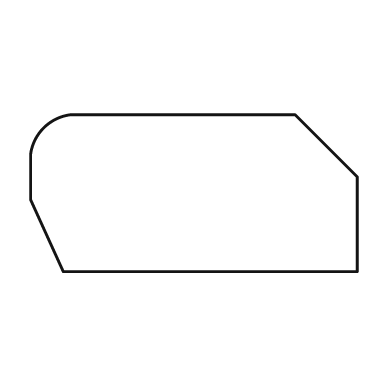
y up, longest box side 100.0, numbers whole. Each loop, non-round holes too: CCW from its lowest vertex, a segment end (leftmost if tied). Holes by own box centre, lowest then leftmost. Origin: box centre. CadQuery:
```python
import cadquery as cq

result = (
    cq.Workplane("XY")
    .moveTo(-40.0, -24.0)
    .lineTo(50.0, -24.0)
    .lineTo(50.0, 5.0)
    .lineTo(31.0, 24.0)
    .lineTo(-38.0, 24.0)
    .threePointArc((-46.0, 20.0), (-50.0, 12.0))
    .lineTo(-50.0, -2.0)
    .close()
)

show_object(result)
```